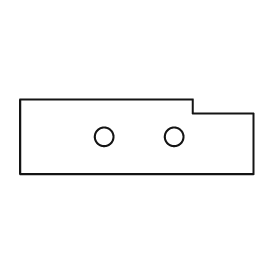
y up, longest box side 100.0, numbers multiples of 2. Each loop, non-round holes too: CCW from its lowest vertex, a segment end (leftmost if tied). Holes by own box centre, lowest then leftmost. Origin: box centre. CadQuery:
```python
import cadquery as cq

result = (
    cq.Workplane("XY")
    .moveTo(-50.0, -16.0)
    .lineTo(50.0, -16.0)
    .lineTo(50.0, 10.0)
    .lineTo(24.0, 10.0)
    .lineTo(24.0, 16.0)
    .lineTo(-50.0, 16.0)
    .close()
    .moveTo(-14.0, 0.0)
    .circle(4.0)
    .moveTo(16.0, 0.0)
    .circle(4.0)
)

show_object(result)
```